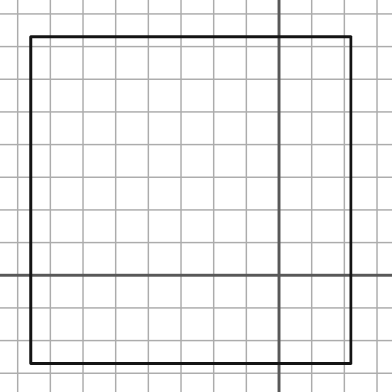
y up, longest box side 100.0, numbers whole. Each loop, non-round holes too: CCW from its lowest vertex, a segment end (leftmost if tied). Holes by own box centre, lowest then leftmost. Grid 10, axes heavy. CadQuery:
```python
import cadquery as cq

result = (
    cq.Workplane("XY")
    .moveTo(-76.0, -27.0)
    .lineTo(22.0, -27.0)
    .lineTo(22.0, 73.0)
    .lineTo(-76.0, 73.0)
    .close()
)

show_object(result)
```